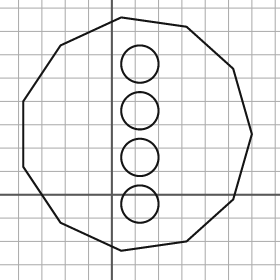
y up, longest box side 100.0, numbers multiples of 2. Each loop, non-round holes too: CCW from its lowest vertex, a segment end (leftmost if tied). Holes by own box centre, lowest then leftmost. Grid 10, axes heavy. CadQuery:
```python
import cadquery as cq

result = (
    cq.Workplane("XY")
    .moveTo(4.0, -24.0)
    .lineTo(32.0, -20.0)
    .lineTo(52.0, -2.0)
    .lineTo(60.0, 26.0)
    .lineTo(52.0, 54.0)
    .lineTo(32.0, 72.0)
    .lineTo(4.0, 76.0)
    .lineTo(-22.0, 64.0)
    .lineTo(-38.0, 40.0)
    .lineTo(-38.0, 12.0)
    .lineTo(-22.0, -12.0)
    .close()
    .moveTo(12.0, -4.0)
    .circle(8.0)
    .moveTo(12.0, 16.0)
    .circle(8.0)
    .moveTo(12.0, 36.0)
    .circle(8.0)
    .moveTo(12.0, 56.0)
    .circle(8.0)
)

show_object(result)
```